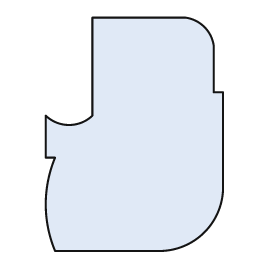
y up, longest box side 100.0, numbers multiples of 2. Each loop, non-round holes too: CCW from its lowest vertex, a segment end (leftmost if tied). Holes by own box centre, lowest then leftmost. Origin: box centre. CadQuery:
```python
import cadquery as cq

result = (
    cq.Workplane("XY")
    .moveTo(-34.0, -50.0)
    .lineTo(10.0, -50.0)
    .threePointArc((30.0, -42.0), (38.0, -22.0))
    .lineTo(38.0, 18.0)
    .lineTo(34.0, 18.0)
    .lineTo(34.0, 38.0)
    .threePointArc((30.0, 46.0), (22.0, 50.0))
    .lineTo(-18.0, 50.0)
    .lineTo(-18.0, 8.0)
    .threePointArc((-28.0, 4.0), (-38.0, 8.0))
    .lineTo(-38.0, -10.0)
    .lineTo(-34.0, -10.0)
    .threePointArc((-38.0, -30.0), (-34.0, -50.0))
    .close()
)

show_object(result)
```